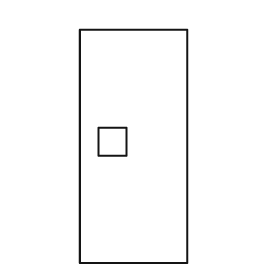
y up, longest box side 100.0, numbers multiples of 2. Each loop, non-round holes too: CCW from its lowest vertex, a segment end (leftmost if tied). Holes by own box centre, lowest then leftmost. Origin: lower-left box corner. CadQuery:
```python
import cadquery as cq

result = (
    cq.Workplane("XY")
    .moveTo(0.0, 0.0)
    .lineTo(46.0, 0.0)
    .lineTo(46.0, 100.0)
    .lineTo(0.0, 100.0)
    .close()
    .moveTo(8.0, 46.0)
    .lineTo(20.0, 46.0)
    .lineTo(20.0, 58.0)
    .lineTo(8.0, 58.0)
    .close()
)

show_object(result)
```